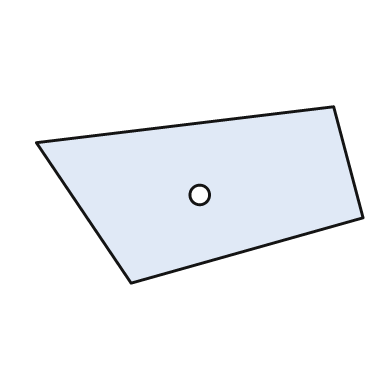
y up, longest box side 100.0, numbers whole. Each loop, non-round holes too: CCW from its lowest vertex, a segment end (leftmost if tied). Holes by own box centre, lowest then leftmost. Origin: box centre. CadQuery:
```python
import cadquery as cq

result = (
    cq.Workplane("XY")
    .moveTo(-21.0, -27.0)
    .lineTo(50.0, -7.0)
    .lineTo(41.0, 27.0)
    .lineTo(-50.0, 16.0)
    .close()
    .moveTo(0.0, 0.0)
    .circle(3.0)
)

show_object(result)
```